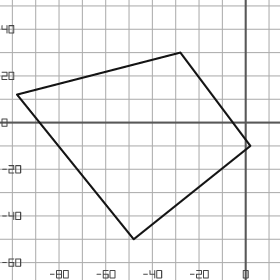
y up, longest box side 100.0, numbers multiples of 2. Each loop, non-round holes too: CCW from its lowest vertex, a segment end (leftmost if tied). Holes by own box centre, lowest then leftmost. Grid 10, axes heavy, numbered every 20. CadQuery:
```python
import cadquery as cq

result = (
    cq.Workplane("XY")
    .moveTo(-48.0, -50.0)
    .lineTo(2.0, -10.0)
    .lineTo(-28.0, 30.0)
    .lineTo(-98.0, 12.0)
    .close()
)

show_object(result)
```